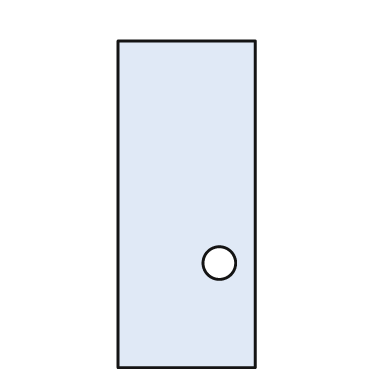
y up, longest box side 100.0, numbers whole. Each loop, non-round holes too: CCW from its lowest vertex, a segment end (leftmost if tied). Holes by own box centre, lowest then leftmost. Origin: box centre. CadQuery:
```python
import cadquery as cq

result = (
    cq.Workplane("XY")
    .moveTo(-21.0, -50.0)
    .lineTo(21.0, -50.0)
    .lineTo(21.0, 50.0)
    .lineTo(-21.0, 50.0)
    .close()
    .moveTo(10.0, -18.0)
    .circle(5.0)
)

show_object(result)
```